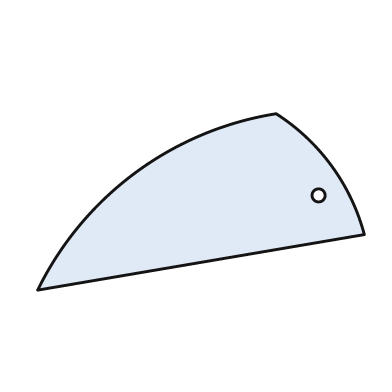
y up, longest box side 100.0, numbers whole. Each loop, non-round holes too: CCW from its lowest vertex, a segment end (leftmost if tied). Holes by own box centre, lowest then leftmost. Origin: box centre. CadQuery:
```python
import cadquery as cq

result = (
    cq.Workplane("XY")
    .moveTo(-50.0, -27.0)
    .lineTo(50.0, -10.0)
    .threePointArc((40.0, 11.0), (23.0, 27.0))
    .threePointArc((-20.0, 9.0), (-50.0, -27.0))
    .close()
    .moveTo(36.0, 2.0)
    .circle(2.0)
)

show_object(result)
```